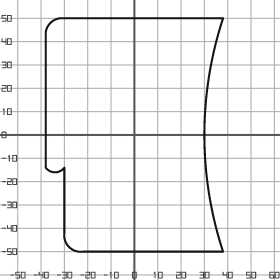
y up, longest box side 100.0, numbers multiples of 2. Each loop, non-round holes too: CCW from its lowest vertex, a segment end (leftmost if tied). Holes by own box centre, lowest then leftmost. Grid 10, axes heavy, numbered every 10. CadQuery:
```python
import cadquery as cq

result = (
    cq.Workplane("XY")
    .moveTo(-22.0, -50.0)
    .lineTo(38.0, -50.0)
    .threePointArc((30.0, 0.0), (38.0, 50.0))
    .lineTo(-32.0, 50.0)
    .threePointArc((-36.0, 48.0), (-38.0, 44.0))
    .lineTo(-38.0, -14.0)
    .threePointArc((-34.0, -16.0), (-30.0, -14.0))
    .lineTo(-30.0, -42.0)
    .threePointArc((-28.0, -48.0), (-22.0, -50.0))
    .close()
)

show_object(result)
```